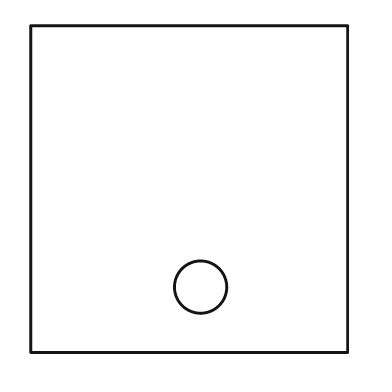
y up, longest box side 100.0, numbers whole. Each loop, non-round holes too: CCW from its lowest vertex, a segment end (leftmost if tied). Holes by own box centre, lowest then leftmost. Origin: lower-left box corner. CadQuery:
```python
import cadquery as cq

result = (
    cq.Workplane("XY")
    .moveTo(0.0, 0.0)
    .lineTo(97.0, 0.0)
    .lineTo(97.0, 100.0)
    .lineTo(0.0, 100.0)
    .close()
    .moveTo(52.0, 20.0)
    .circle(8.0)
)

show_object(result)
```